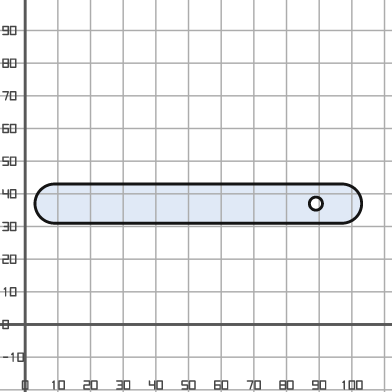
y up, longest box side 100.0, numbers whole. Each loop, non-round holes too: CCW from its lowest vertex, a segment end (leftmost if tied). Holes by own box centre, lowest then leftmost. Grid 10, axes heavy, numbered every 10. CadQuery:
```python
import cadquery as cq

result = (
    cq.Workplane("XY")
    .moveTo(9.0, 31.0)
    .lineTo(97.0, 31.0)
    .threePointArc((103.0, 37.0), (97.0, 43.0))
    .lineTo(9.0, 43.0)
    .threePointArc((3.0, 37.0), (9.0, 31.0))
    .close()
    .moveTo(89.0, 37.0)
    .circle(2.0)
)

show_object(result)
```